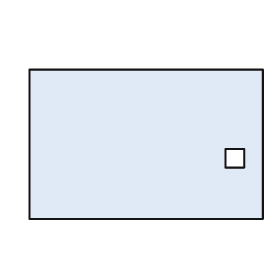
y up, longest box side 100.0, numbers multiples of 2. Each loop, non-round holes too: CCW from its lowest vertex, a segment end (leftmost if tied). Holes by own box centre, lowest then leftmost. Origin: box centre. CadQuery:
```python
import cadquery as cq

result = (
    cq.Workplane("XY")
    .moveTo(-50.0, -32.0)
    .lineTo(50.0, -32.0)
    .lineTo(50.0, 32.0)
    .lineTo(-50.0, 32.0)
    .close()
    .moveTo(34.0, -10.0)
    .lineTo(42.0, -10.0)
    .lineTo(42.0, -2.0)
    .lineTo(34.0, -2.0)
    .close()
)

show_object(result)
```